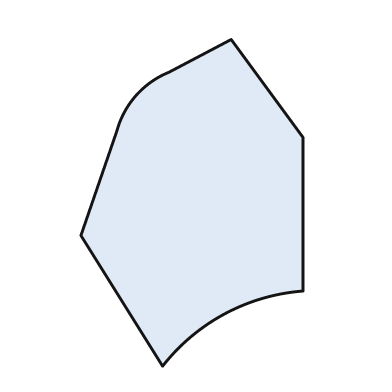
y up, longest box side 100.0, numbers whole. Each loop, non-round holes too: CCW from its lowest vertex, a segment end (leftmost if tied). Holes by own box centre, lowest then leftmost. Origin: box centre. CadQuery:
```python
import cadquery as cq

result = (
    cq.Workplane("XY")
    .moveTo(-9.0, -50.0)
    .threePointArc((10.0, -34.0), (34.0, -27.0))
    .lineTo(34.0, 20.0)
    .lineTo(12.0, 50.0)
    .lineTo(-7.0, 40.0)
    .threePointArc((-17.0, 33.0), (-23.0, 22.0))
    .lineTo(-34.0, -10.0)
    .close()
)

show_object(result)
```